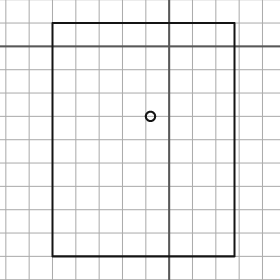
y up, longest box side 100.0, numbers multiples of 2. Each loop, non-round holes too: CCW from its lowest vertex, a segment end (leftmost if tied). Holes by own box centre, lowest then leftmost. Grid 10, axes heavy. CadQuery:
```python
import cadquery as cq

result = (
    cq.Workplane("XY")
    .moveTo(-50.0, -90.0)
    .lineTo(28.0, -90.0)
    .lineTo(28.0, 10.0)
    .lineTo(-50.0, 10.0)
    .close()
    .moveTo(-8.0, -30.0)
    .circle(2.0)
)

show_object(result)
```